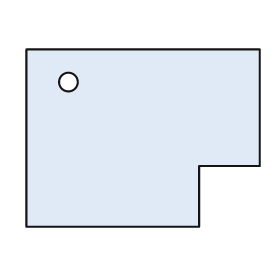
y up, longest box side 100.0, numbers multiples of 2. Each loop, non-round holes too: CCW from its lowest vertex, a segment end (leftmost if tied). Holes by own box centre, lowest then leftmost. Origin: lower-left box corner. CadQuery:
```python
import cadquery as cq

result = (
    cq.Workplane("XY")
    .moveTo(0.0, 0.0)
    .lineTo(74.0, 0.0)
    .lineTo(74.0, 26.0)
    .lineTo(100.0, 26.0)
    .lineTo(100.0, 76.0)
    .lineTo(0.0, 76.0)
    .close()
    .moveTo(18.0, 62.0)
    .circle(4.0)
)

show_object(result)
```